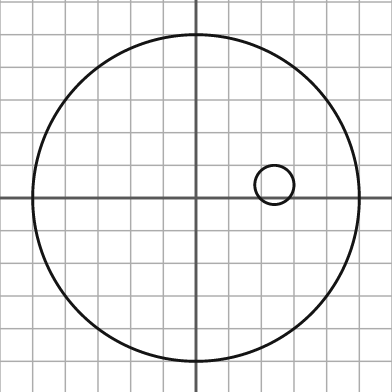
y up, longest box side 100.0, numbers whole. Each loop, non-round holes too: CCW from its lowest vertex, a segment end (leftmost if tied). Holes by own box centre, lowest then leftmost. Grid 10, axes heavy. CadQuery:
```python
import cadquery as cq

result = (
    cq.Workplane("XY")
    .moveTo(0.0, 0.0)
    .circle(50.0)
    .moveTo(24.0, 4.0)
    .circle(6.0)
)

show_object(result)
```